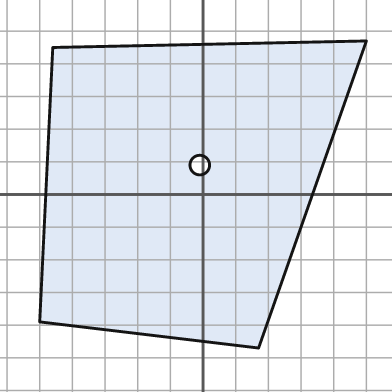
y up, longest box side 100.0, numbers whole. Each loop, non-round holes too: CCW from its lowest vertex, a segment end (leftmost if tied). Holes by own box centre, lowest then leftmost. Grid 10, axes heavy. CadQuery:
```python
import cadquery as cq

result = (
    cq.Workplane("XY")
    .moveTo(17.0, -47.0)
    .lineTo(50.0, 47.0)
    .lineTo(-46.0, 45.0)
    .lineTo(-50.0, -39.0)
    .close()
    .moveTo(-1.0, 9.0)
    .circle(3.0)
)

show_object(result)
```